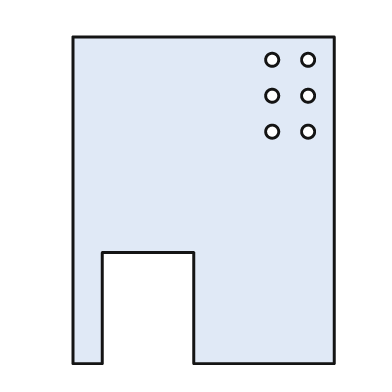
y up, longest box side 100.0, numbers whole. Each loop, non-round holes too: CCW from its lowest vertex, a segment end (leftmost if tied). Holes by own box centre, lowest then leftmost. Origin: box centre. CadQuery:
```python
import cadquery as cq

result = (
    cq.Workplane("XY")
    .moveTo(-40.0, -50.0)
    .lineTo(-31.0, -50.0)
    .lineTo(-31.0, -16.0)
    .lineTo(-3.0, -16.0)
    .lineTo(-3.0, -50.0)
    .lineTo(40.0, -50.0)
    .lineTo(40.0, 50.0)
    .lineTo(-40.0, 50.0)
    .close()
    .moveTo(21.0, 21.0)
    .circle(2.0)
    .moveTo(32.0, 21.0)
    .circle(2.0)
    .moveTo(21.0, 32.0)
    .circle(2.0)
    .moveTo(32.0, 32.0)
    .circle(2.0)
    .moveTo(21.0, 43.0)
    .circle(2.0)
    .moveTo(32.0, 43.0)
    .circle(2.0)
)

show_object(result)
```